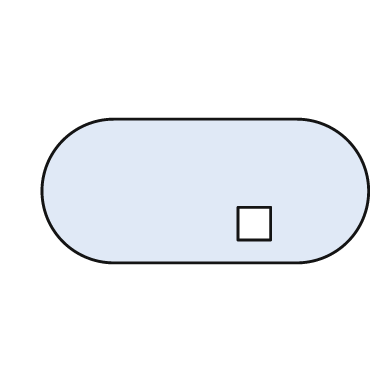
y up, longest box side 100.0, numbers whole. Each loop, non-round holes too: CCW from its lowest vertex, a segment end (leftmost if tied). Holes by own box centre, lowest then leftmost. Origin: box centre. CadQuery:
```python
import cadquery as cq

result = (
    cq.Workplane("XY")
    .moveTo(-28.0, -22.0)
    .lineTo(28.0, -22.0)
    .threePointArc((50.0, 0.0), (28.0, 22.0))
    .lineTo(-28.0, 22.0)
    .threePointArc((-50.0, 0.0), (-28.0, -22.0))
    .close()
    .moveTo(10.0, -15.0)
    .lineTo(20.0, -15.0)
    .lineTo(20.0, -5.0)
    .lineTo(10.0, -5.0)
    .close()
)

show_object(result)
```